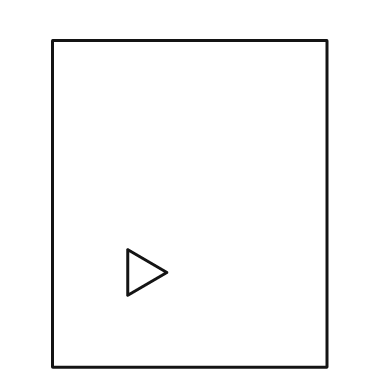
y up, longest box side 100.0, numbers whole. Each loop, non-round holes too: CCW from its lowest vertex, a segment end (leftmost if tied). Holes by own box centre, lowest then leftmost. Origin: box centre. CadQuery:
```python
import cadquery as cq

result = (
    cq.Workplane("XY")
    .moveTo(-42.0, -50.0)
    .lineTo(42.0, -50.0)
    .lineTo(42.0, 50.0)
    .lineTo(-42.0, 50.0)
    .close()
    .moveTo(-19.0, -28.0)
    .lineTo(-7.0, -21.0)
    .lineTo(-19.0, -14.0)
    .close()
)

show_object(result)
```